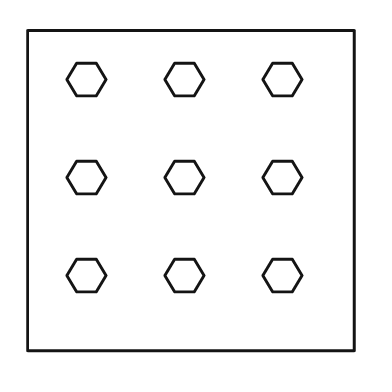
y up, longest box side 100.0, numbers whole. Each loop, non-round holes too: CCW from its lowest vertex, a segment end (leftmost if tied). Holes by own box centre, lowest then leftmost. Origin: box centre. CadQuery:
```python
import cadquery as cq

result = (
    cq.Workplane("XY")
    .moveTo(-50.0, -49.0)
    .lineTo(50.0, -49.0)
    .lineTo(50.0, 49.0)
    .lineTo(-50.0, 49.0)
    .close()
    .moveTo(-35.0, -31.0)
    .lineTo(-29.0, -31.0)
    .lineTo(-26.0, -26.0)
    .lineTo(-29.0, -21.0)
    .lineTo(-35.0, -21.0)
    .lineTo(-38.0, -26.0)
    .close()
    .moveTo(-5.0, -31.0)
    .lineTo(1.0, -31.0)
    .lineTo(4.0, -26.0)
    .lineTo(1.0, -21.0)
    .lineTo(-5.0, -21.0)
    .lineTo(-8.0, -26.0)
    .close()
    .moveTo(25.0, -31.0)
    .lineTo(31.0, -31.0)
    .lineTo(34.0, -26.0)
    .lineTo(31.0, -21.0)
    .lineTo(25.0, -21.0)
    .lineTo(22.0, -26.0)
    .close()
    .moveTo(-35.0, -1.0)
    .lineTo(-29.0, -1.0)
    .lineTo(-26.0, 4.0)
    .lineTo(-29.0, 9.0)
    .lineTo(-35.0, 9.0)
    .lineTo(-38.0, 4.0)
    .close()
    .moveTo(-5.0, -1.0)
    .lineTo(1.0, -1.0)
    .lineTo(4.0, 4.0)
    .lineTo(1.0, 9.0)
    .lineTo(-5.0, 9.0)
    .lineTo(-8.0, 4.0)
    .close()
    .moveTo(25.0, -1.0)
    .lineTo(31.0, -1.0)
    .lineTo(34.0, 4.0)
    .lineTo(31.0, 9.0)
    .lineTo(25.0, 9.0)
    .lineTo(22.0, 4.0)
    .close()
    .moveTo(-35.0, 29.0)
    .lineTo(-29.0, 29.0)
    .lineTo(-26.0, 34.0)
    .lineTo(-29.0, 39.0)
    .lineTo(-35.0, 39.0)
    .lineTo(-38.0, 34.0)
    .close()
    .moveTo(-5.0, 29.0)
    .lineTo(1.0, 29.0)
    .lineTo(4.0, 34.0)
    .lineTo(1.0, 39.0)
    .lineTo(-5.0, 39.0)
    .lineTo(-8.0, 34.0)
    .close()
    .moveTo(25.0, 29.0)
    .lineTo(31.0, 29.0)
    .lineTo(34.0, 34.0)
    .lineTo(31.0, 39.0)
    .lineTo(25.0, 39.0)
    .lineTo(22.0, 34.0)
    .close()
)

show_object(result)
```